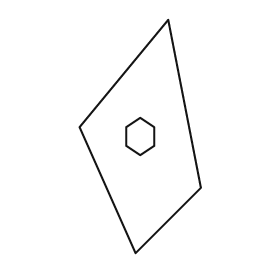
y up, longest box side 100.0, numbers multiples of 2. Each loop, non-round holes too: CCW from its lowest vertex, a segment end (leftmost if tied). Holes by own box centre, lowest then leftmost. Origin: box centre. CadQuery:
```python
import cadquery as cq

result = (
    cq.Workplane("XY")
    .moveTo(-2.0, -50.0)
    .lineTo(26.0, -22.0)
    .lineTo(12.0, 50.0)
    .lineTo(-26.0, 4.0)
    .close()
    .moveTo(0.0, -8.0)
    .lineTo(6.0, -4.0)
    .lineTo(6.0, 4.0)
    .lineTo(0.0, 8.0)
    .lineTo(-6.0, 4.0)
    .lineTo(-6.0, -4.0)
    .close()
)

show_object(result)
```